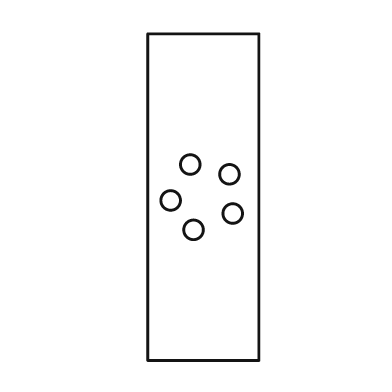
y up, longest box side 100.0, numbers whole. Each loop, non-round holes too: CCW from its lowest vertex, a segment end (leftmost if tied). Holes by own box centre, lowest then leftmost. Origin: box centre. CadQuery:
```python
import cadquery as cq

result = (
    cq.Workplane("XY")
    .moveTo(-17.0, -50.0)
    .lineTo(17.0, -50.0)
    .lineTo(17.0, 50.0)
    .lineTo(-17.0, 50.0)
    .close()
    .moveTo(-3.0, -10.0)
    .circle(3.0)
    .moveTo(9.0, -5.0)
    .circle(3.0)
    .moveTo(-10.0, -1.0)
    .circle(3.0)
    .moveTo(8.0, 7.0)
    .circle(3.0)
    .moveTo(-4.0, 10.0)
    .circle(3.0)
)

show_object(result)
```